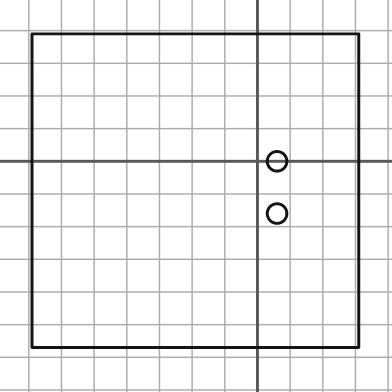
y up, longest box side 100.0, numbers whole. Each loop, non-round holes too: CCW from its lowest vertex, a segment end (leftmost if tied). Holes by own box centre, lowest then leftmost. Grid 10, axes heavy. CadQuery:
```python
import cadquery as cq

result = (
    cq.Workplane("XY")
    .moveTo(-69.0, -57.0)
    .lineTo(31.0, -57.0)
    .lineTo(31.0, 39.0)
    .lineTo(-69.0, 39.0)
    .close()
    .moveTo(6.0, -16.0)
    .circle(3.0)
    .moveTo(6.0, 0.0)
    .circle(3.0)
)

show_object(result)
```